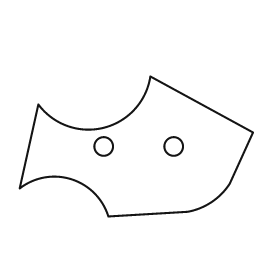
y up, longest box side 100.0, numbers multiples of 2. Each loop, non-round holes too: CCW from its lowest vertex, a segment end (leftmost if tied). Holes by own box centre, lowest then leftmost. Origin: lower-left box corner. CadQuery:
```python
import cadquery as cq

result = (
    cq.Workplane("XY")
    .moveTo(38.0, 0.0)
    .lineTo(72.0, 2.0)
    .threePointArc((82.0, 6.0), (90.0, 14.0))
    .lineTo(100.0, 36.0)
    .lineTo(56.0, 60.0)
    .threePointArc((36.0, 38.0), (8.0, 48.0))
    .lineTo(0.0, 12.0)
    .threePointArc((22.0, 16.0), (38.0, 0.0))
    .close()
    .moveTo(36.0, 30.0)
    .circle(4.0)
    .moveTo(66.0, 30.0)
    .circle(4.0)
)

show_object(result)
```